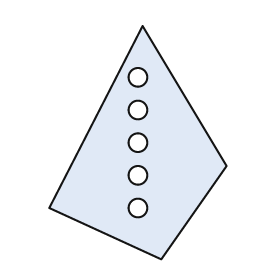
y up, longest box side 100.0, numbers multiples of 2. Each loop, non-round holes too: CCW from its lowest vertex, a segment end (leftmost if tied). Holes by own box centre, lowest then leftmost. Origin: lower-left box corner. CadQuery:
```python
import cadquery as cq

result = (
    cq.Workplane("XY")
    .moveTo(48.0, 0.0)
    .lineTo(76.0, 40.0)
    .lineTo(40.0, 100.0)
    .lineTo(0.0, 22.0)
    .close()
    .moveTo(38.0, 22.0)
    .circle(4.0)
    .moveTo(38.0, 36.0)
    .circle(4.0)
    .moveTo(38.0, 50.0)
    .circle(4.0)
    .moveTo(38.0, 64.0)
    .circle(4.0)
    .moveTo(38.0, 78.0)
    .circle(4.0)
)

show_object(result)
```